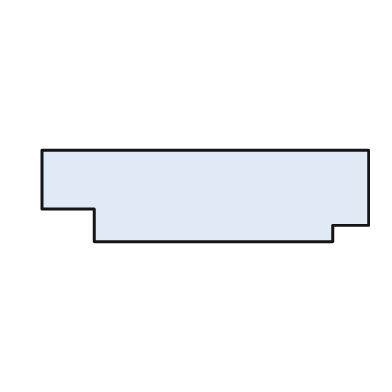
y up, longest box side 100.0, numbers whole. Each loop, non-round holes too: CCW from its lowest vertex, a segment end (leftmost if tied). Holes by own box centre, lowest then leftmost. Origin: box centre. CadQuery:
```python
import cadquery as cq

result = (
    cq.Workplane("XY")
    .moveTo(-34.0, -14.0)
    .lineTo(39.0, -14.0)
    .lineTo(39.0, -9.0)
    .lineTo(50.0, -9.0)
    .lineTo(50.0, 14.0)
    .lineTo(-50.0, 14.0)
    .lineTo(-50.0, -4.0)
    .lineTo(-34.0, -4.0)
    .close()
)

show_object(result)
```